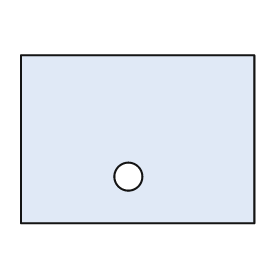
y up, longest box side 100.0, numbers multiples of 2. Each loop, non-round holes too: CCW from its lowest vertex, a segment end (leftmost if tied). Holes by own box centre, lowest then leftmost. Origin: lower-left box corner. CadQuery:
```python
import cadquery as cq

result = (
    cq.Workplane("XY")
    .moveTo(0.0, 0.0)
    .lineTo(100.0, 0.0)
    .lineTo(100.0, 72.0)
    .lineTo(0.0, 72.0)
    .close()
    .moveTo(46.0, 20.0)
    .circle(6.0)
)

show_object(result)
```